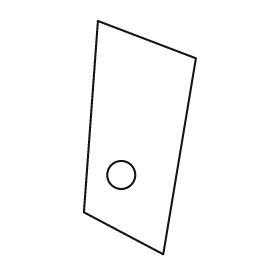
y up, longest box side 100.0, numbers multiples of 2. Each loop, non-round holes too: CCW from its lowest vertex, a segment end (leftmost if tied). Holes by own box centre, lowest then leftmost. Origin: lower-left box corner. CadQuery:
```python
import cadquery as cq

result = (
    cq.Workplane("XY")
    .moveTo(34.0, 0.0)
    .lineTo(48.0, 84.0)
    .lineTo(6.0, 100.0)
    .lineTo(0.0, 18.0)
    .close()
    .moveTo(16.0, 34.0)
    .circle(6.0)
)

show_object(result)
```